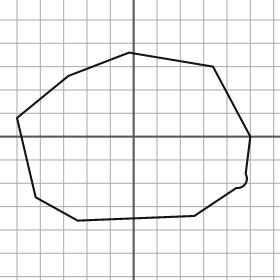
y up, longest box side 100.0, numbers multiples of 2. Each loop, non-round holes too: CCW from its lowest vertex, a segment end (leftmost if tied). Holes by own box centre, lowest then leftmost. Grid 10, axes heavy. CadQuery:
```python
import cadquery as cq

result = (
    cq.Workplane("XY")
    .moveTo(-24.0, -36.0)
    .lineTo(26.0, -34.0)
    .lineTo(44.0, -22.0)
    .threePointArc((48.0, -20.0), (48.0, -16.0))
    .lineTo(50.0, 0.0)
    .lineTo(34.0, 30.0)
    .lineTo(-2.0, 36.0)
    .lineTo(-28.0, 26.0)
    .lineTo(-50.0, 8.0)
    .lineTo(-42.0, -26.0)
    .close()
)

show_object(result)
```